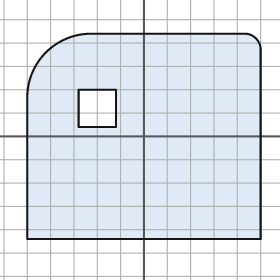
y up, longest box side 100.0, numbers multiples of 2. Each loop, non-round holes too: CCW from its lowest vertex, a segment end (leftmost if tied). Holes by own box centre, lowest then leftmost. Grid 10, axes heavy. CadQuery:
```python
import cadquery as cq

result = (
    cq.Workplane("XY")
    .moveTo(-50.0, -44.0)
    .lineTo(50.0, -44.0)
    .lineTo(50.0, 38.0)
    .threePointArc((48.0, 42.0), (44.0, 44.0))
    .lineTo(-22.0, 44.0)
    .threePointArc((-42.0, 36.0), (-50.0, 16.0))
    .close()
    .moveTo(-28.0, 4.0)
    .lineTo(-12.0, 4.0)
    .lineTo(-12.0, 20.0)
    .lineTo(-28.0, 20.0)
    .close()
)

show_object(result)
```